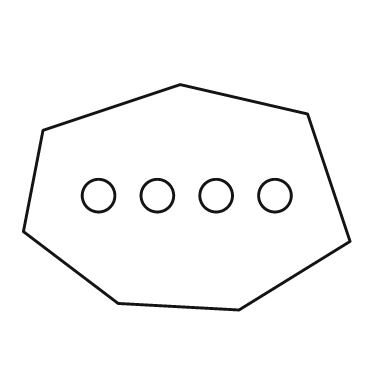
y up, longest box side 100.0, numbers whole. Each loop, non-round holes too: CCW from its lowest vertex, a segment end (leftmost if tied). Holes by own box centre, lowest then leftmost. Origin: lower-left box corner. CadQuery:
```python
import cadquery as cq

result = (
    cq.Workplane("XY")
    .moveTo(66.0, 0.0)
    .lineTo(100.0, 21.0)
    .lineTo(87.0, 60.0)
    .lineTo(48.0, 69.0)
    .lineTo(6.0, 55.0)
    .lineTo(0.0, 24.0)
    .lineTo(29.0, 2.0)
    .close()
    .moveTo(23.0, 35.0)
    .circle(5.0)
    .moveTo(41.0, 35.0)
    .circle(5.0)
    .moveTo(59.0, 35.0)
    .circle(5.0)
    .moveTo(77.0, 35.0)
    .circle(5.0)
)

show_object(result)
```